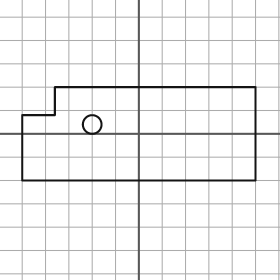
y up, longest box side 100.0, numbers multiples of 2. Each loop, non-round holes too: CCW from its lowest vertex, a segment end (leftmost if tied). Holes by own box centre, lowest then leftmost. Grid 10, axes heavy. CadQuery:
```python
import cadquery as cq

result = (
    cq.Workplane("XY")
    .moveTo(-50.0, -20.0)
    .lineTo(50.0, -20.0)
    .lineTo(50.0, 20.0)
    .lineTo(-36.0, 20.0)
    .lineTo(-36.0, 8.0)
    .lineTo(-50.0, 8.0)
    .close()
    .moveTo(-20.0, 4.0)
    .circle(4.0)
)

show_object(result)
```